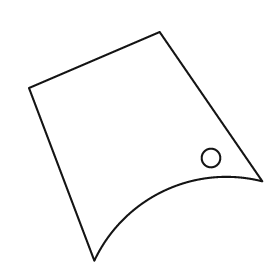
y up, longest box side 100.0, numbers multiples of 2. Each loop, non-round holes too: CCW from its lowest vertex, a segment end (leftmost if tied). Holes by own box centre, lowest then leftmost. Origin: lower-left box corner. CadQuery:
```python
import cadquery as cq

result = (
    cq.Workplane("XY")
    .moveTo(28.0, 0.0)
    .threePointArc((58.0, 30.0), (100.0, 34.0))
    .lineTo(56.0, 98.0)
    .lineTo(0.0, 74.0)
    .close()
    .moveTo(78.0, 44.0)
    .circle(4.0)
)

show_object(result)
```